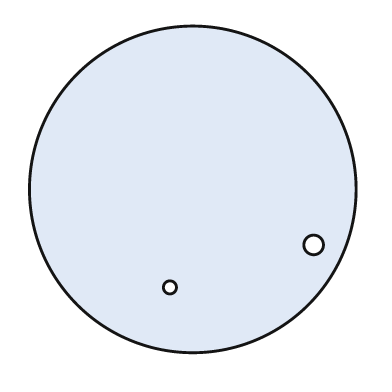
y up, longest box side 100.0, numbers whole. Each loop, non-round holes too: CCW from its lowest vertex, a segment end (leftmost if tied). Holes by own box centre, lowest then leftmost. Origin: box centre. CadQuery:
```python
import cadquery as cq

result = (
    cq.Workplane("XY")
    .moveTo(0.0, 0.0)
    .circle(50.0)
    .moveTo(-7.0, -30.0)
    .circle(2.0)
    .moveTo(37.0, -17.0)
    .circle(3.0)
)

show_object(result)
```